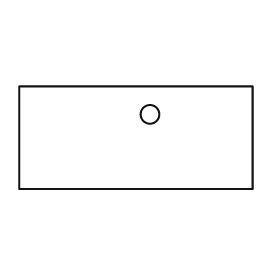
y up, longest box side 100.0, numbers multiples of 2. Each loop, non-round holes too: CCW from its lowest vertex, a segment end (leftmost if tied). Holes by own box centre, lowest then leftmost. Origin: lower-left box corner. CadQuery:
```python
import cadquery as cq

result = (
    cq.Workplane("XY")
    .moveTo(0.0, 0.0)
    .lineTo(100.0, 0.0)
    .lineTo(100.0, 44.0)
    .lineTo(0.0, 44.0)
    .close()
    .moveTo(56.0, 32.0)
    .circle(4.0)
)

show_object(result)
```